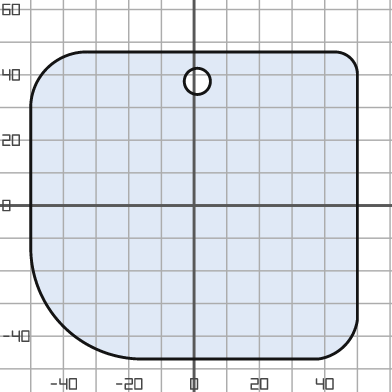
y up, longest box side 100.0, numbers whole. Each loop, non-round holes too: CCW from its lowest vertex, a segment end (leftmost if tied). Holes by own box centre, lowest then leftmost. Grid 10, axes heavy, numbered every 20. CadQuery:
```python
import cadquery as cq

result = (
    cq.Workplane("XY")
    .moveTo(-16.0, -47.0)
    .lineTo(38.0, -47.0)
    .threePointArc((46.0, -43.0), (50.0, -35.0))
    .lineTo(50.0, 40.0)
    .threePointArc((48.0, 45.0), (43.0, 47.0))
    .lineTo(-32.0, 47.0)
    .threePointArc((-45.0, 42.0), (-50.0, 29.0))
    .lineTo(-50.0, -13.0)
    .threePointArc((-40.0, -37.0), (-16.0, -47.0))
    .close()
    .moveTo(1.0, 38.0)
    .circle(4.0)
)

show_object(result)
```